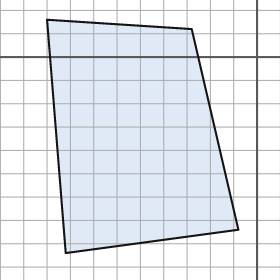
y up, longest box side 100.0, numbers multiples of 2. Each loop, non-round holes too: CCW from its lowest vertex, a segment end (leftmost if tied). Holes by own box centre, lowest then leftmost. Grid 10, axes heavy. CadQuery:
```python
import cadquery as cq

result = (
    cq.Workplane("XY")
    .moveTo(-82.0, -84.0)
    .lineTo(-8.0, -74.0)
    .lineTo(-28.0, 12.0)
    .lineTo(-90.0, 16.0)
    .close()
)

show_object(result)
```